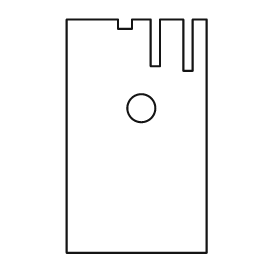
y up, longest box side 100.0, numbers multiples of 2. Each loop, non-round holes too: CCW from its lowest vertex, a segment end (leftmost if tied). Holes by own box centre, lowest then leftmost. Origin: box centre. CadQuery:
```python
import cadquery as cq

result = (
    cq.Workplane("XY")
    .moveTo(-30.0, -50.0)
    .lineTo(30.0, -50.0)
    .lineTo(30.0, 50.0)
    .lineTo(24.0, 50.0)
    .lineTo(24.0, 28.0)
    .lineTo(20.0, 28.0)
    .lineTo(20.0, 50.0)
    .lineTo(10.0, 50.0)
    .lineTo(10.0, 30.0)
    .lineTo(6.0, 30.0)
    .lineTo(6.0, 50.0)
    .lineTo(-2.0, 50.0)
    .lineTo(-2.0, 46.0)
    .lineTo(-8.0, 46.0)
    .lineTo(-8.0, 50.0)
    .lineTo(-30.0, 50.0)
    .close()
    .moveTo(2.0, 12.0)
    .circle(6.0)
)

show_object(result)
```